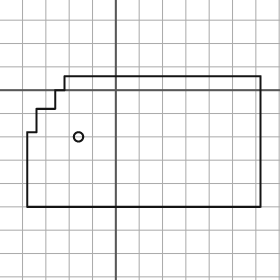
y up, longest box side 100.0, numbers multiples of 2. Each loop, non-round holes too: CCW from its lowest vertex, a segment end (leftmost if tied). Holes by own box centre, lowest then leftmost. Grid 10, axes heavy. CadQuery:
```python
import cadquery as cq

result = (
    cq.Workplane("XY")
    .moveTo(-38.0, -50.0)
    .lineTo(62.0, -50.0)
    .lineTo(62.0, 6.0)
    .lineTo(-22.0, 6.0)
    .lineTo(-22.0, 0.0)
    .lineTo(-26.0, 0.0)
    .lineTo(-26.0, -8.0)
    .lineTo(-34.0, -8.0)
    .lineTo(-34.0, -18.0)
    .lineTo(-38.0, -18.0)
    .close()
    .moveTo(-16.0, -20.0)
    .circle(2.0)
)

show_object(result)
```